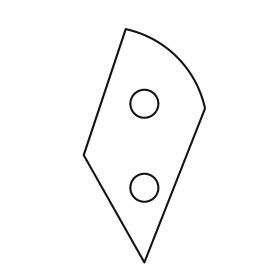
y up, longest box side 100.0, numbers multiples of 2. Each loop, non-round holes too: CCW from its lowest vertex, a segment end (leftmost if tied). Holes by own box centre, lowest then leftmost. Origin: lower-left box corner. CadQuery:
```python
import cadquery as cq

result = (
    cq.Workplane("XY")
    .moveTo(26.0, 0.0)
    .lineTo(52.0, 66.0)
    .threePointArc((40.0, 88.0), (18.0, 100.0))
    .lineTo(0.0, 46.0)
    .close()
    .moveTo(26.0, 32.0)
    .circle(6.0)
    .moveTo(26.0, 68.0)
    .circle(6.0)
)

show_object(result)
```